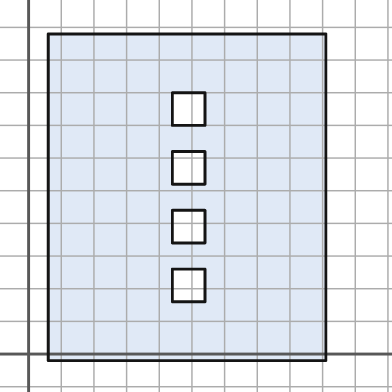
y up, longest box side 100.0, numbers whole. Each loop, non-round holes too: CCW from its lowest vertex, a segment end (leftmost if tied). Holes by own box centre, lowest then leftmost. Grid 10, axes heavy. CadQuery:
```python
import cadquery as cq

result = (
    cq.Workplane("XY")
    .moveTo(6.0, -2.0)
    .lineTo(91.0, -2.0)
    .lineTo(91.0, 98.0)
    .lineTo(6.0, 98.0)
    .close()
    .moveTo(44.0, 16.0)
    .lineTo(54.0, 16.0)
    .lineTo(54.0, 26.0)
    .lineTo(44.0, 26.0)
    .close()
    .moveTo(44.0, 34.0)
    .lineTo(54.0, 34.0)
    .lineTo(54.0, 44.0)
    .lineTo(44.0, 44.0)
    .close()
    .moveTo(44.0, 52.0)
    .lineTo(54.0, 52.0)
    .lineTo(54.0, 62.0)
    .lineTo(44.0, 62.0)
    .close()
    .moveTo(44.0, 70.0)
    .lineTo(54.0, 70.0)
    .lineTo(54.0, 80.0)
    .lineTo(44.0, 80.0)
    .close()
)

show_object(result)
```